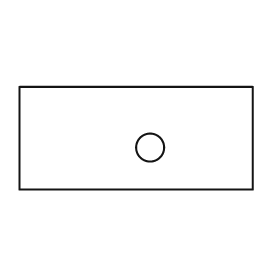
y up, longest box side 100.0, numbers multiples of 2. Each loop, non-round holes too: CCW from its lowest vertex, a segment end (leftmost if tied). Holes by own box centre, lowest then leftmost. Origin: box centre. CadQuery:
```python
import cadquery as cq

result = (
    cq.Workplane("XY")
    .moveTo(-50.0, -22.0)
    .lineTo(50.0, -22.0)
    .lineTo(50.0, 22.0)
    .lineTo(-50.0, 22.0)
    .close()
    .moveTo(6.0, -4.0)
    .circle(6.0)
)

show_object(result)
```